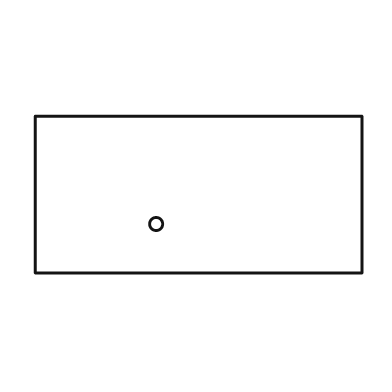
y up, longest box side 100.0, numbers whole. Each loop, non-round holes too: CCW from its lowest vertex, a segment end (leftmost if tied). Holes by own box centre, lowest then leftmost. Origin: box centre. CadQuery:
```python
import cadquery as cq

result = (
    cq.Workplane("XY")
    .moveTo(-50.0, -24.0)
    .lineTo(50.0, -24.0)
    .lineTo(50.0, 24.0)
    .lineTo(-50.0, 24.0)
    .close()
    .moveTo(-13.0, -9.0)
    .circle(2.0)
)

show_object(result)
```